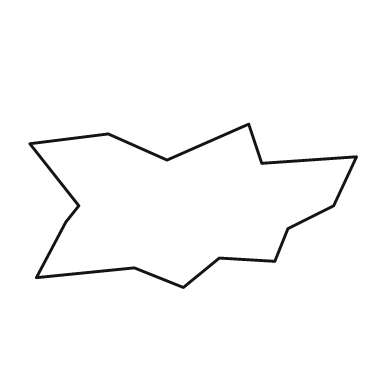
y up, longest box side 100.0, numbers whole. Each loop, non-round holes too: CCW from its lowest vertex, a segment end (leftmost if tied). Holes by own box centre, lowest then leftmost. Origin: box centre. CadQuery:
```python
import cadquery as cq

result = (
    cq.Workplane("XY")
    .moveTo(-3.0, -25.0)
    .lineTo(8.0, -16.0)
    .lineTo(25.0, -17.0)
    .lineTo(29.0, -7.0)
    .lineTo(43.0, 0.0)
    .lineTo(50.0, 15.0)
    .lineTo(21.0, 13.0)
    .lineTo(17.0, 25.0)
    .lineTo(-8.0, 14.0)
    .lineTo(-26.0, 22.0)
    .lineTo(-50.0, 19.0)
    .lineTo(-35.0, 0.0)
    .lineTo(-39.0, -5.0)
    .lineTo(-48.0, -22.0)
    .lineTo(-18.0, -19.0)
    .close()
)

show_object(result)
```